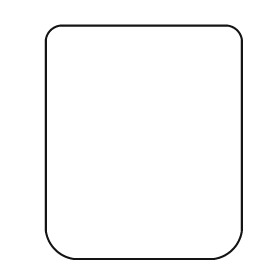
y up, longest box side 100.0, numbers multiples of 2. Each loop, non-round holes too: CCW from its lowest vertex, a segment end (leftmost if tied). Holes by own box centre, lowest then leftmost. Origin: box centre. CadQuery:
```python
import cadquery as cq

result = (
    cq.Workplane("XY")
    .moveTo(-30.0, -50.0)
    .lineTo(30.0, -50.0)
    .threePointArc((38.0, -46.0), (42.0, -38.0))
    .lineTo(42.0, 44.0)
    .threePointArc((40.0, 48.0), (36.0, 50.0))
    .lineTo(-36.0, 50.0)
    .threePointArc((-40.0, 48.0), (-42.0, 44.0))
    .lineTo(-42.0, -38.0)
    .threePointArc((-38.0, -46.0), (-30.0, -50.0))
    .close()
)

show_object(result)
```